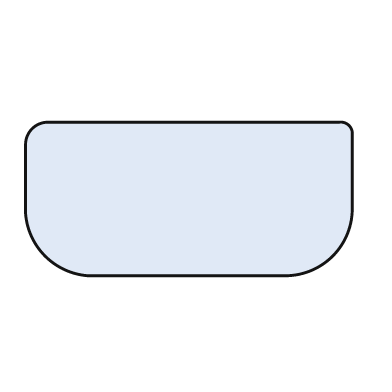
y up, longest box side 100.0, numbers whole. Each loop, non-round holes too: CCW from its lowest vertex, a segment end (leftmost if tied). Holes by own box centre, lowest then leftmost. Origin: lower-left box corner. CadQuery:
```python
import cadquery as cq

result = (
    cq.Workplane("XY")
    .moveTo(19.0, 0.0)
    .lineTo(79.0, 0.0)
    .threePointArc((94.0, 6.0), (100.0, 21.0))
    .lineTo(100.0, 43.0)
    .threePointArc((99.0, 46.0), (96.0, 47.0))
    .lineTo(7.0, 47.0)
    .threePointArc((2.0, 45.0), (0.0, 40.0))
    .lineTo(0.0, 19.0)
    .threePointArc((6.0, 6.0), (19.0, 0.0))
    .close()
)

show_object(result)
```